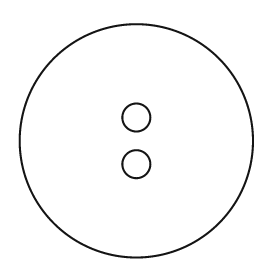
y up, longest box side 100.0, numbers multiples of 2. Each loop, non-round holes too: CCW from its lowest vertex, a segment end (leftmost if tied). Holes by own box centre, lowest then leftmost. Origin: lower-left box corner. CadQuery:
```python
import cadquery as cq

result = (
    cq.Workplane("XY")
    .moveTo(50.0, 50.0)
    .circle(50.0)
    .moveTo(50.0, 40.0)
    .circle(6.0)
    .moveTo(50.0, 60.0)
    .circle(6.0)
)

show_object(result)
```